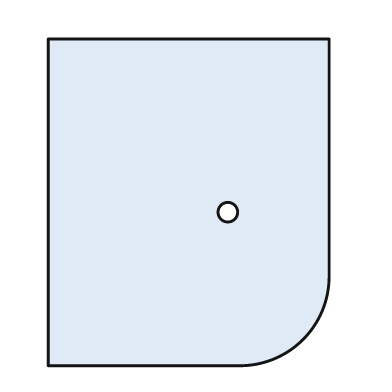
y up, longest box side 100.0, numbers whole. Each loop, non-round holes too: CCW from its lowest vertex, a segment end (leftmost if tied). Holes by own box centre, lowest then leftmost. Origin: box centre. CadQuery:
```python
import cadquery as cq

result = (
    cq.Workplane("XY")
    .moveTo(-43.0, -50.0)
    .lineTo(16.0, -50.0)
    .threePointArc((35.0, -42.0), (43.0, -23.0))
    .lineTo(43.0, 50.0)
    .lineTo(-43.0, 50.0)
    .close()
    .moveTo(12.0, -3.0)
    .circle(3.0)
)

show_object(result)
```